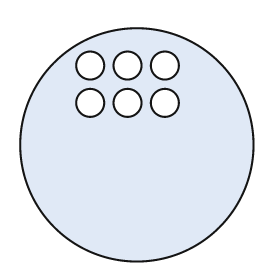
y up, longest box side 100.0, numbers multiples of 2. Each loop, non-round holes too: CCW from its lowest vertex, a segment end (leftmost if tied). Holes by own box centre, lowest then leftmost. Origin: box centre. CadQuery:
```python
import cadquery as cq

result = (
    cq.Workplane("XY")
    .moveTo(0.0, 0.0)
    .circle(50.0)
    .moveTo(-20.0, 18.0)
    .circle(6.0)
    .moveTo(-4.0, 18.0)
    .circle(6.0)
    .moveTo(12.0, 18.0)
    .circle(6.0)
    .moveTo(-20.0, 34.0)
    .circle(6.0)
    .moveTo(-4.0, 34.0)
    .circle(6.0)
    .moveTo(12.0, 34.0)
    .circle(6.0)
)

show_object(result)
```